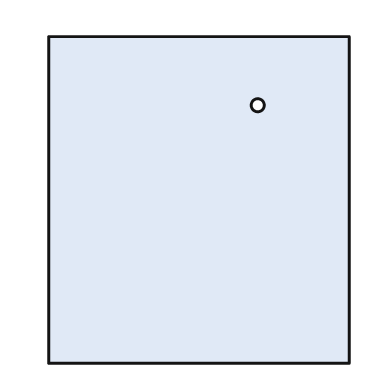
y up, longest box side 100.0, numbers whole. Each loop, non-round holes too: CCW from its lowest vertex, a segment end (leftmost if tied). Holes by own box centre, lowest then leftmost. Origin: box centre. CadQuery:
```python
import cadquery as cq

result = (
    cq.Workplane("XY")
    .moveTo(-46.0, -50.0)
    .lineTo(46.0, -50.0)
    .lineTo(46.0, 50.0)
    .lineTo(-46.0, 50.0)
    .close()
    .moveTo(18.0, 29.0)
    .circle(2.0)
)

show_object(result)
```